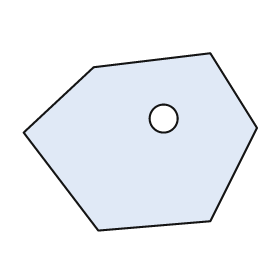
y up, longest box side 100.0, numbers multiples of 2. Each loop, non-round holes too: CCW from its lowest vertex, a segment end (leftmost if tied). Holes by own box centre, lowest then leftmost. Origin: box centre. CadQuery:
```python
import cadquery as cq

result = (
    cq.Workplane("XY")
    .moveTo(-18.0, -38.0)
    .lineTo(30.0, -34.0)
    .lineTo(50.0, 6.0)
    .lineTo(30.0, 38.0)
    .lineTo(-20.0, 32.0)
    .lineTo(-50.0, 4.0)
    .close()
    .moveTo(10.0, 10.0)
    .circle(6.0)
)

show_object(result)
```